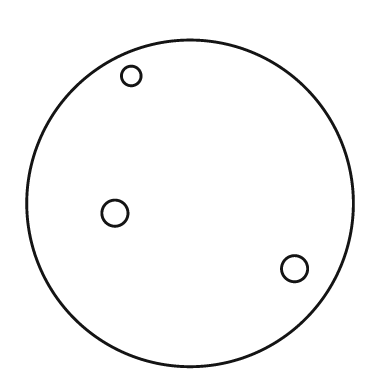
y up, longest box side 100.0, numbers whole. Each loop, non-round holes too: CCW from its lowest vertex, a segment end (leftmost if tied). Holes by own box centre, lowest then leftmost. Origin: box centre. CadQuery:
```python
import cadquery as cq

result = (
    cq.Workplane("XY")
    .moveTo(0.0, 0.0)
    .circle(50.0)
    .moveTo(32.0, -20.0)
    .circle(4.0)
    .moveTo(-23.0, -3.0)
    .circle(4.0)
    .moveTo(-18.0, 39.0)
    .circle(3.0)
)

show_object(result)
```